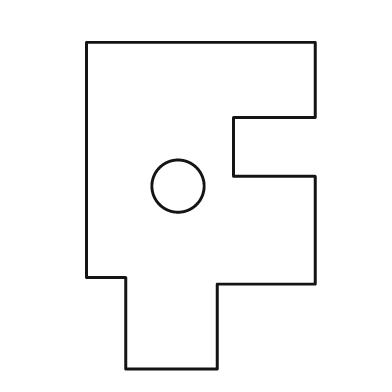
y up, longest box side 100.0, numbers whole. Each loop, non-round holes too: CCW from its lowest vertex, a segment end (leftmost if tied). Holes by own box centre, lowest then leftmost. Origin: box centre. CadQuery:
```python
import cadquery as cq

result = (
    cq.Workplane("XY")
    .moveTo(-23.0, -50.0)
    .lineTo(5.0, -50.0)
    .lineTo(5.0, -24.0)
    .lineTo(35.0, -24.0)
    .lineTo(35.0, 9.0)
    .lineTo(10.0, 9.0)
    .lineTo(10.0, 27.0)
    .lineTo(35.0, 27.0)
    .lineTo(35.0, 50.0)
    .lineTo(-35.0, 50.0)
    .lineTo(-35.0, -22.0)
    .lineTo(-23.0, -22.0)
    .close()
    .moveTo(-7.0, 6.0)
    .circle(8.0)
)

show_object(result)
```